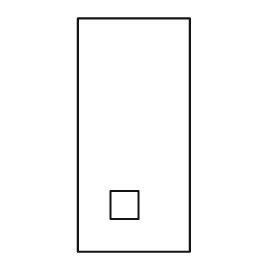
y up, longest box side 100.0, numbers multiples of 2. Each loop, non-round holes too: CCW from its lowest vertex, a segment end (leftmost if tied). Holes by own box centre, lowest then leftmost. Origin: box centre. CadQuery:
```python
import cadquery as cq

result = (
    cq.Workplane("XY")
    .moveTo(-24.0, -50.0)
    .lineTo(24.0, -50.0)
    .lineTo(24.0, 50.0)
    .lineTo(-24.0, 50.0)
    .close()
    .moveTo(-10.0, -36.0)
    .lineTo(2.0, -36.0)
    .lineTo(2.0, -24.0)
    .lineTo(-10.0, -24.0)
    .close()
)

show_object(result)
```